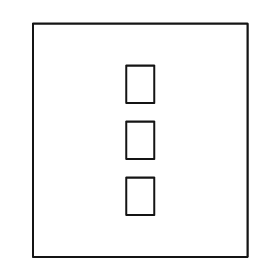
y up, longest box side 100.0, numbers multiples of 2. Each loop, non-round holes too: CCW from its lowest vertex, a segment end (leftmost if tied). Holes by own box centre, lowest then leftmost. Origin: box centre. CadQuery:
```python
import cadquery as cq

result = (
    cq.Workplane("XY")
    .moveTo(-46.0, -50.0)
    .lineTo(46.0, -50.0)
    .lineTo(46.0, 50.0)
    .lineTo(-46.0, 50.0)
    .close()
    .moveTo(-6.0, -32.0)
    .lineTo(6.0, -32.0)
    .lineTo(6.0, -16.0)
    .lineTo(-6.0, -16.0)
    .close()
    .moveTo(-6.0, -8.0)
    .lineTo(6.0, -8.0)
    .lineTo(6.0, 8.0)
    .lineTo(-6.0, 8.0)
    .close()
    .moveTo(-6.0, 16.0)
    .lineTo(6.0, 16.0)
    .lineTo(6.0, 32.0)
    .lineTo(-6.0, 32.0)
    .close()
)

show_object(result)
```